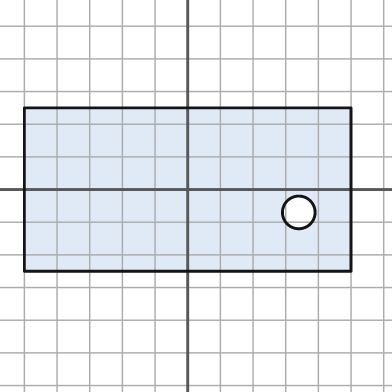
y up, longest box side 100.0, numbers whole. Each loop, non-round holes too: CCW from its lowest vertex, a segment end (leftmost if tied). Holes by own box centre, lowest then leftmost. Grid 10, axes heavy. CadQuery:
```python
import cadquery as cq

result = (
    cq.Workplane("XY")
    .moveTo(-50.0, -25.0)
    .lineTo(50.0, -25.0)
    .lineTo(50.0, 25.0)
    .lineTo(-50.0, 25.0)
    .close()
    .moveTo(34.0, -7.0)
    .circle(5.0)
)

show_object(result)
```